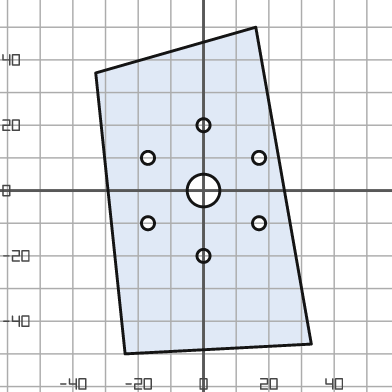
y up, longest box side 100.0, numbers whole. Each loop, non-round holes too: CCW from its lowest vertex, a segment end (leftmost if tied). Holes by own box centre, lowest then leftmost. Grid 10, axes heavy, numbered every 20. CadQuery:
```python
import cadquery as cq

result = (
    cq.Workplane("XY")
    .moveTo(-24.0, -50.0)
    .lineTo(33.0, -47.0)
    .lineTo(16.0, 50.0)
    .lineTo(-33.0, 36.0)
    .close()
    .moveTo(0.0, -20.0)
    .circle(2.0)
    .moveTo(-17.0, -10.0)
    .circle(2.0)
    .moveTo(17.0, -10.0)
    .circle(2.0)
    .moveTo(0.0, 0.0)
    .circle(5.0)
    .moveTo(-17.0, 10.0)
    .circle(2.0)
    .moveTo(17.0, 10.0)
    .circle(2.0)
    .moveTo(0.0, 20.0)
    .circle(2.0)
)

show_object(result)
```